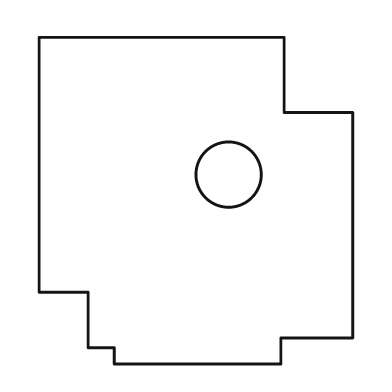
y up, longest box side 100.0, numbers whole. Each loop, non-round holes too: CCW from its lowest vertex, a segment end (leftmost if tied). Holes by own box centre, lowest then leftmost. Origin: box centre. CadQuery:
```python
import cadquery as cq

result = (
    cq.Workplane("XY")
    .moveTo(-25.0, -50.0)
    .lineTo(26.0, -50.0)
    .lineTo(26.0, -42.0)
    .lineTo(48.0, -42.0)
    .lineTo(48.0, 27.0)
    .lineTo(27.0, 27.0)
    .lineTo(27.0, 50.0)
    .lineTo(-48.0, 50.0)
    .lineTo(-48.0, -28.0)
    .lineTo(-33.0, -28.0)
    .lineTo(-33.0, -45.0)
    .lineTo(-25.0, -45.0)
    .close()
    .moveTo(10.0, 8.0)
    .circle(10.0)
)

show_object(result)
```